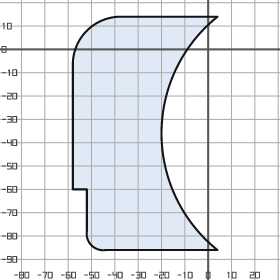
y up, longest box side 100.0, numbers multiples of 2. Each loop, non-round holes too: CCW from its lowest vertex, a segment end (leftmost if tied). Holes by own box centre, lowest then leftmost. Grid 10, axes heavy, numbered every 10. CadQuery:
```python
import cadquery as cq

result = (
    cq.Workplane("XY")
    .moveTo(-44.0, -86.0)
    .lineTo(4.0, -86.0)
    .threePointArc((-20.0, -36.0), (4.0, 14.0))
    .lineTo(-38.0, 14.0)
    .threePointArc((-52.0, 8.0), (-58.0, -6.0))
    .lineTo(-58.0, -60.0)
    .lineTo(-52.0, -60.0)
    .lineTo(-52.0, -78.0)
    .threePointArc((-50.0, -84.0), (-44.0, -86.0))
    .close()
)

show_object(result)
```